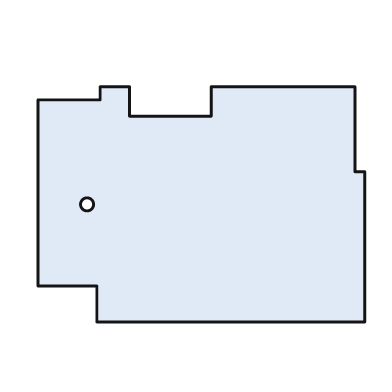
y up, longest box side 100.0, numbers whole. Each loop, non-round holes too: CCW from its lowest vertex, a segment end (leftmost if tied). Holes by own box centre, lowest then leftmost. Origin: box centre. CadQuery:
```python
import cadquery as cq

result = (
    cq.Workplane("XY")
    .moveTo(-32.0, -36.0)
    .lineTo(50.0, -36.0)
    .lineTo(50.0, 10.0)
    .lineTo(47.0, 10.0)
    .lineTo(47.0, 36.0)
    .lineTo(3.0, 36.0)
    .lineTo(3.0, 27.0)
    .lineTo(-22.0, 27.0)
    .lineTo(-22.0, 36.0)
    .lineTo(-31.0, 36.0)
    .lineTo(-31.0, 32.0)
    .lineTo(-50.0, 32.0)
    .lineTo(-50.0, -25.0)
    .lineTo(-32.0, -25.0)
    .close()
    .moveTo(-35.0, 0.0)
    .circle(2.0)
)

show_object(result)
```